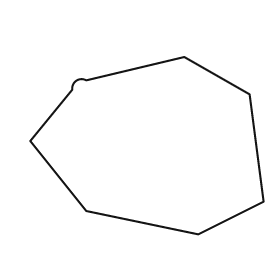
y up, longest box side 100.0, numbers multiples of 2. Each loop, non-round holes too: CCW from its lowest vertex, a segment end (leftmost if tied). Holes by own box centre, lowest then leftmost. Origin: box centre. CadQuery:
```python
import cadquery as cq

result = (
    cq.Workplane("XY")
    .moveTo(22.0, -38.0)
    .lineTo(50.0, -24.0)
    .lineTo(44.0, 22.0)
    .lineTo(16.0, 38.0)
    .lineTo(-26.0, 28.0)
    .threePointArc((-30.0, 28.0), (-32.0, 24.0))
    .lineTo(-50.0, 2.0)
    .lineTo(-26.0, -28.0)
    .close()
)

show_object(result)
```